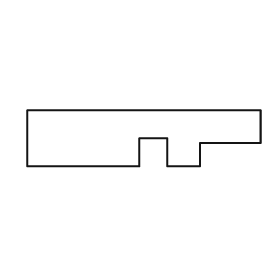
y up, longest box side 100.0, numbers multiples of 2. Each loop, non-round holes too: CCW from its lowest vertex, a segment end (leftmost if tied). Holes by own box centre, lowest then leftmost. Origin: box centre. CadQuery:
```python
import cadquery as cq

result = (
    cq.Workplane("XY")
    .moveTo(-50.0, -12.0)
    .lineTo(-2.0, -12.0)
    .lineTo(-2.0, 0.0)
    .lineTo(10.0, 0.0)
    .lineTo(10.0, -12.0)
    .lineTo(24.0, -12.0)
    .lineTo(24.0, -2.0)
    .lineTo(50.0, -2.0)
    .lineTo(50.0, 12.0)
    .lineTo(-50.0, 12.0)
    .close()
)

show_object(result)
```